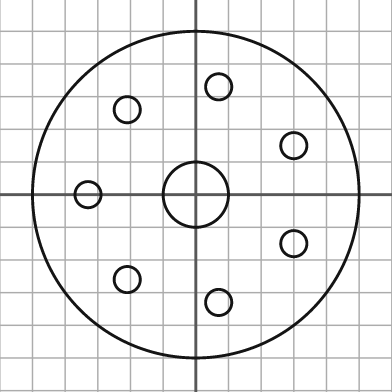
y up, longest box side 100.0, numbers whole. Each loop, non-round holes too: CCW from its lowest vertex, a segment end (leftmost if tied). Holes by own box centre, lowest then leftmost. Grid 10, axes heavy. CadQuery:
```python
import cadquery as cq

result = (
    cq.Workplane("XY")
    .moveTo(0.0, 0.0)
    .circle(50.0)
    .moveTo(7.0, -33.0)
    .circle(4.0)
    .moveTo(-21.0, -26.0)
    .circle(4.0)
    .moveTo(30.0, -15.0)
    .circle(4.0)
    .moveTo(-33.0, 0.0)
    .circle(4.0)
    .moveTo(0.0, 0.0)
    .circle(10.0)
    .moveTo(30.0, 15.0)
    .circle(4.0)
    .moveTo(-21.0, 26.0)
    .circle(4.0)
    .moveTo(7.0, 33.0)
    .circle(4.0)
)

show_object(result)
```